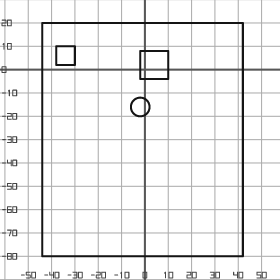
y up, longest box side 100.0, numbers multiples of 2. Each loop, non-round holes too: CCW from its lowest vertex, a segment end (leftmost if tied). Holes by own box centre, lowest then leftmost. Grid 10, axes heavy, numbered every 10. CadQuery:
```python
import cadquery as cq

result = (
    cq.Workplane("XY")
    .moveTo(-44.0, -80.0)
    .lineTo(42.0, -80.0)
    .lineTo(42.0, 20.0)
    .lineTo(-44.0, 20.0)
    .close()
    .moveTo(-2.0, -16.0)
    .circle(4.0)
    .moveTo(-2.0, -4.0)
    .lineTo(10.0, -4.0)
    .lineTo(10.0, 8.0)
    .lineTo(-2.0, 8.0)
    .close()
    .moveTo(-38.0, 2.0)
    .lineTo(-30.0, 2.0)
    .lineTo(-30.0, 10.0)
    .lineTo(-38.0, 10.0)
    .close()
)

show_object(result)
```